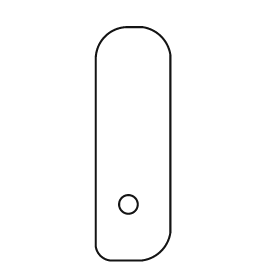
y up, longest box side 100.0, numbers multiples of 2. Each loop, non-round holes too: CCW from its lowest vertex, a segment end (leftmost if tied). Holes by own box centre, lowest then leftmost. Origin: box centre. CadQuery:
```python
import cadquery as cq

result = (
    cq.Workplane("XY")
    .moveTo(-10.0, -50.0)
    .lineTo(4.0, -50.0)
    .threePointArc((12.0, -46.0), (16.0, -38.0))
    .lineTo(16.0, 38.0)
    .threePointArc((12.0, 46.0), (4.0, 50.0))
    .lineTo(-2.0, 50.0)
    .threePointArc((-12.0, 46.0), (-16.0, 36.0))
    .lineTo(-16.0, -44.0)
    .threePointArc((-14.0, -48.0), (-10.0, -50.0))
    .close()
    .moveTo(-2.0, -26.0)
    .circle(4.0)
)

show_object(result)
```